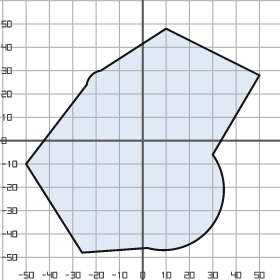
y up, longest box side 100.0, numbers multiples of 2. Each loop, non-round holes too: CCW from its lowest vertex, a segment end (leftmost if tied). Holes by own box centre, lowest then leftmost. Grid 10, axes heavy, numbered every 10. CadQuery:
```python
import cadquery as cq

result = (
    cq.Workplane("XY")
    .moveTo(-26.0, -48.0)
    .lineTo(2.0, -46.0)
    .threePointArc((30.0, -36.0), (30.0, -6.0))
    .lineTo(50.0, 28.0)
    .lineTo(10.0, 48.0)
    .lineTo(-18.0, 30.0)
    .threePointArc((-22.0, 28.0), (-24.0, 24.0))
    .lineTo(-50.0, -10.0)
    .close()
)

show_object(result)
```